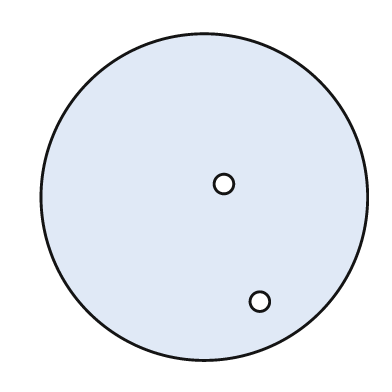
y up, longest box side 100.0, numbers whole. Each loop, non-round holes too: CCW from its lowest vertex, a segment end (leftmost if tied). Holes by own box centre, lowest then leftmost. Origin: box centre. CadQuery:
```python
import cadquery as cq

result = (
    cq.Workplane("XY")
    .moveTo(0.0, 0.0)
    .circle(50.0)
    .moveTo(17.0, -32.0)
    .circle(3.0)
    .moveTo(6.0, 4.0)
    .circle(3.0)
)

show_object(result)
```